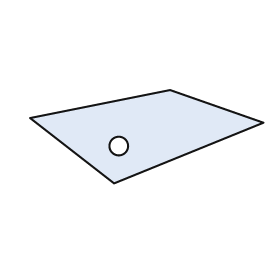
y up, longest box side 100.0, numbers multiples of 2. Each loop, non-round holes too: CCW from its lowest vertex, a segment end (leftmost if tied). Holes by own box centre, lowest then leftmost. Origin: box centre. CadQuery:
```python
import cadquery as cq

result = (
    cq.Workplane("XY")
    .moveTo(-14.0, -20.0)
    .lineTo(50.0, 6.0)
    .lineTo(10.0, 20.0)
    .lineTo(-50.0, 8.0)
    .close()
    .moveTo(-12.0, -4.0)
    .circle(4.0)
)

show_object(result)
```